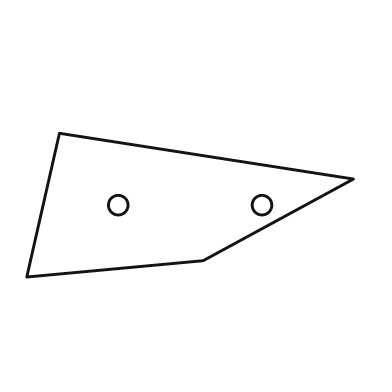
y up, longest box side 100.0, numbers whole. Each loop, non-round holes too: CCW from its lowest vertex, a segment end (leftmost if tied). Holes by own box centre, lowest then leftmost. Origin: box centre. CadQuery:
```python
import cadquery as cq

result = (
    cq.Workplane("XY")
    .moveTo(-50.0, -22.0)
    .lineTo(4.0, -17.0)
    .lineTo(50.0, 8.0)
    .lineTo(-40.0, 22.0)
    .close()
    .moveTo(-22.0, 0.0)
    .circle(3.0)
    .moveTo(22.0, 0.0)
    .circle(3.0)
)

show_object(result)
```